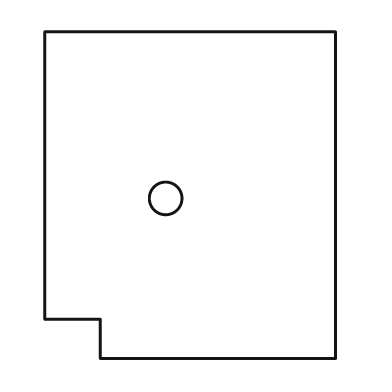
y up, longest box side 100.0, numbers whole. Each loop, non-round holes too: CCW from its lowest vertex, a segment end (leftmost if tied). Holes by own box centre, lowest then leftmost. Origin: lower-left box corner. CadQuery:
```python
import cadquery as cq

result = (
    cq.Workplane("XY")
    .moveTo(17.0, 0.0)
    .lineTo(89.0, 0.0)
    .lineTo(89.0, 100.0)
    .lineTo(0.0, 100.0)
    .lineTo(0.0, 12.0)
    .lineTo(17.0, 12.0)
    .close()
    .moveTo(37.0, 49.0)
    .circle(5.0)
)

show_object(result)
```